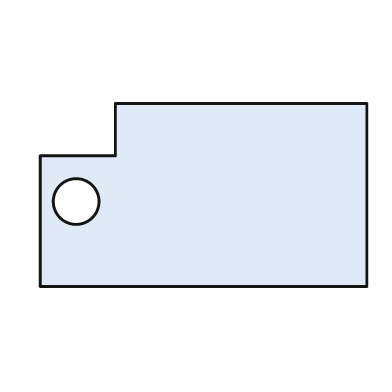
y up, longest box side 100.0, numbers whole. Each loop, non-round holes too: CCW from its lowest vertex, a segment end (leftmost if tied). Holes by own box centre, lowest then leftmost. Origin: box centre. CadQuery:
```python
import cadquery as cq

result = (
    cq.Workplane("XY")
    .moveTo(-50.0, -28.0)
    .lineTo(50.0, -28.0)
    .lineTo(50.0, 28.0)
    .lineTo(-27.0, 28.0)
    .lineTo(-27.0, 12.0)
    .lineTo(-50.0, 12.0)
    .close()
    .moveTo(-39.0, -2.0)
    .circle(7.0)
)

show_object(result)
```